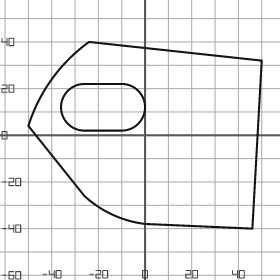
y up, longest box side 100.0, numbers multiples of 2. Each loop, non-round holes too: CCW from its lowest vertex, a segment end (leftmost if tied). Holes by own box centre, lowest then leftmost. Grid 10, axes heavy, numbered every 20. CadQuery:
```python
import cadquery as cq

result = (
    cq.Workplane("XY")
    .moveTo(46.0, -40.0)
    .lineTo(50.0, 32.0)
    .lineTo(-24.0, 40.0)
    .threePointArc((-40.0, 24.0), (-50.0, 4.0))
    .lineTo(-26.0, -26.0)
    .threePointArc((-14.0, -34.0), (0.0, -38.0))
    .close()
    .moveTo(-26.0, 2.0)
    .lineTo(-10.0, 2.0)
    .threePointArc((0.0, 12.0), (-10.0, 22.0))
    .lineTo(-26.0, 22.0)
    .threePointArc((-36.0, 12.0), (-26.0, 2.0))
    .close()
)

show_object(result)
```